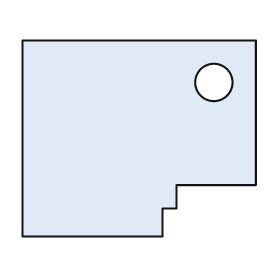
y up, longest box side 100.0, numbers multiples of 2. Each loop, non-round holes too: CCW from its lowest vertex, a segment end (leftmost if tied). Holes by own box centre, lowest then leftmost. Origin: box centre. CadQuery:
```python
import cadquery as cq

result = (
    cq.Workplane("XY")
    .moveTo(-50.0, -42.0)
    .lineTo(10.0, -42.0)
    .lineTo(10.0, -30.0)
    .lineTo(16.0, -30.0)
    .lineTo(16.0, -20.0)
    .lineTo(50.0, -20.0)
    .lineTo(50.0, 42.0)
    .lineTo(-50.0, 42.0)
    .close()
    .moveTo(32.0, 24.0)
    .circle(8.0)
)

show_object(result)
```